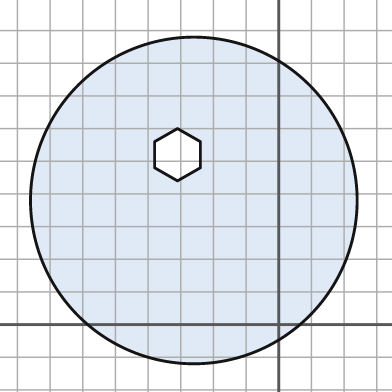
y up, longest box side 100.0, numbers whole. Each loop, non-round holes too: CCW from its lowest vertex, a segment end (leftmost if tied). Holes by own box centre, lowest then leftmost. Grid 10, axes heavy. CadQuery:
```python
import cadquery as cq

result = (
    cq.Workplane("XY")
    .moveTo(-26.0, 38.0)
    .circle(50.0)
    .moveTo(-31.0, 44.0)
    .lineTo(-24.0, 48.0)
    .lineTo(-24.0, 56.0)
    .lineTo(-31.0, 60.0)
    .lineTo(-38.0, 56.0)
    .lineTo(-38.0, 48.0)
    .close()
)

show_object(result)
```